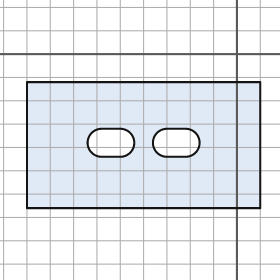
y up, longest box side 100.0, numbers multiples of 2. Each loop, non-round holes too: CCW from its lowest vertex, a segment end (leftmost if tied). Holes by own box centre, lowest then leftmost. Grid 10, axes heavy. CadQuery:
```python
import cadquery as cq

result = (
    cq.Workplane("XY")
    .moveTo(-90.0, -66.0)
    .lineTo(10.0, -66.0)
    .lineTo(10.0, -12.0)
    .lineTo(-90.0, -12.0)
    .close()
    .moveTo(-58.0, -44.0)
    .lineTo(-50.0, -44.0)
    .threePointArc((-44.0, -38.0), (-50.0, -32.0))
    .lineTo(-58.0, -32.0)
    .threePointArc((-64.0, -38.0), (-58.0, -44.0))
    .close()
    .moveTo(-30.0, -44.0)
    .lineTo(-22.0, -44.0)
    .threePointArc((-16.0, -38.0), (-22.0, -32.0))
    .lineTo(-30.0, -32.0)
    .threePointArc((-36.0, -38.0), (-30.0, -44.0))
    .close()
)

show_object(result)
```